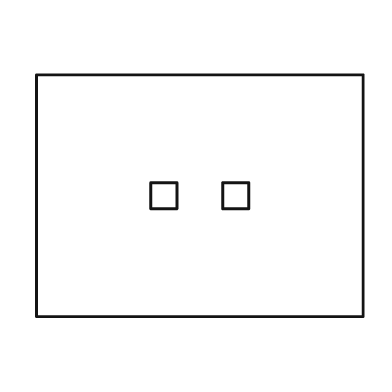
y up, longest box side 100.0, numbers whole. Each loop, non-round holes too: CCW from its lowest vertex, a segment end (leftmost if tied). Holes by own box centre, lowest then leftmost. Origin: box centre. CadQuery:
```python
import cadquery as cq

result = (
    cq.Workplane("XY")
    .moveTo(-50.0, -37.0)
    .lineTo(50.0, -37.0)
    .lineTo(50.0, 37.0)
    .lineTo(-50.0, 37.0)
    .close()
    .moveTo(-15.0, -4.0)
    .lineTo(-7.0, -4.0)
    .lineTo(-7.0, 4.0)
    .lineTo(-15.0, 4.0)
    .close()
    .moveTo(7.0, -4.0)
    .lineTo(15.0, -4.0)
    .lineTo(15.0, 4.0)
    .lineTo(7.0, 4.0)
    .close()
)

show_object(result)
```